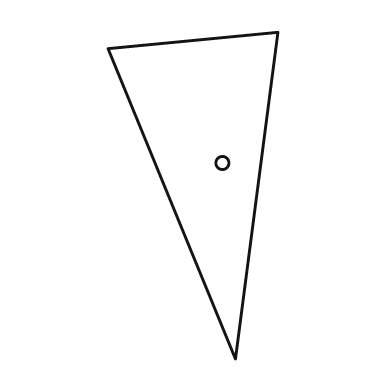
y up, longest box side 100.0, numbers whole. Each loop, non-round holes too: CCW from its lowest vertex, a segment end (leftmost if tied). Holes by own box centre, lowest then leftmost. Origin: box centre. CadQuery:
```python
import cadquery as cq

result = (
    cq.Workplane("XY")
    .moveTo(13.0, -50.0)
    .lineTo(26.0, 50.0)
    .lineTo(-26.0, 45.0)
    .close()
    .moveTo(9.0, 10.0)
    .circle(2.0)
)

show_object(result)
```